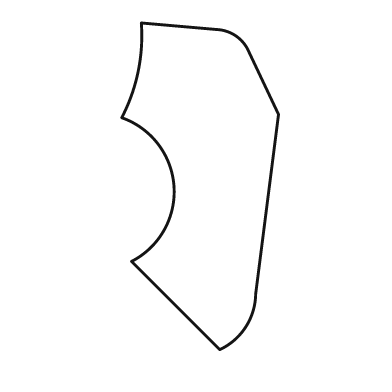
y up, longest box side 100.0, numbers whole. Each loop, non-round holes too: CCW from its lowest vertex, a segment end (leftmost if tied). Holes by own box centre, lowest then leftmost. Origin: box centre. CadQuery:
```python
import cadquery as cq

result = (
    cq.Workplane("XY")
    .moveTo(6.0, -50.0)
    .threePointArc((14.0, -43.0), (17.0, -33.0))
    .lineTo(24.0, 22.0)
    .lineTo(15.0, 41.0)
    .threePointArc((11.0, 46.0), (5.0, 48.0))
    .lineTo(-18.0, 50.0)
    .threePointArc((-19.0, 35.0), (-24.0, 21.0))
    .threePointArc((-8.0, 0.0), (-21.0, -23.0))
    .close()
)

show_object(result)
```